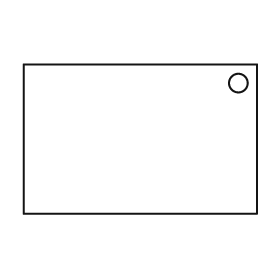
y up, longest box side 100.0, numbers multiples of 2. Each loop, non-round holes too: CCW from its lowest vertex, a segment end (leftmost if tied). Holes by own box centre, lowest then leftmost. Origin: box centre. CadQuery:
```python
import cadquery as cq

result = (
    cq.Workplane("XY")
    .moveTo(-50.0, -32.0)
    .lineTo(50.0, -32.0)
    .lineTo(50.0, 32.0)
    .lineTo(-50.0, 32.0)
    .close()
    .moveTo(42.0, 24.0)
    .circle(4.0)
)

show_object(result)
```